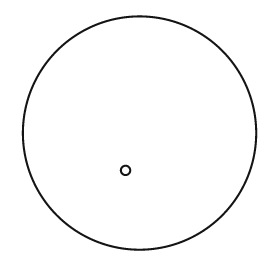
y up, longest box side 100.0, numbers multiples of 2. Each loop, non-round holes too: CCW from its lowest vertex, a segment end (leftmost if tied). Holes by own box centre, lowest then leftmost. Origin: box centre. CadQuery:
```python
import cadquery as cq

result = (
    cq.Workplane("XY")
    .moveTo(0.0, 0.0)
    .circle(50.0)
    .moveTo(-6.0, -16.0)
    .circle(2.0)
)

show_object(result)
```